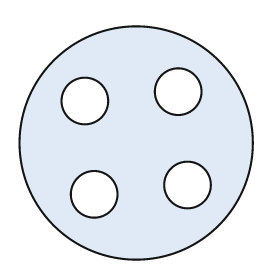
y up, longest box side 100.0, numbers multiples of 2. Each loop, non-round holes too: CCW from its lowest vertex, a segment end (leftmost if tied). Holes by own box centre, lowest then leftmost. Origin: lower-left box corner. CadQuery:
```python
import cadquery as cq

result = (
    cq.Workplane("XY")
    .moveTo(50.0, 50.0)
    .circle(50.0)
    .moveTo(32.0, 28.0)
    .circle(10.0)
    .moveTo(72.0, 32.0)
    .circle(10.0)
    .moveTo(28.0, 68.0)
    .circle(10.0)
    .moveTo(68.0, 72.0)
    .circle(10.0)
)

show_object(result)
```